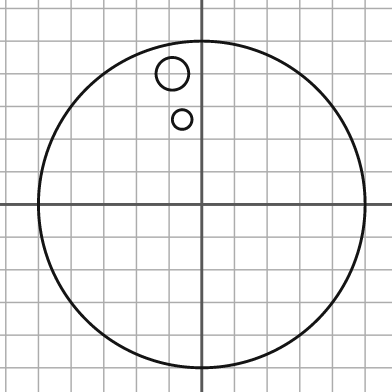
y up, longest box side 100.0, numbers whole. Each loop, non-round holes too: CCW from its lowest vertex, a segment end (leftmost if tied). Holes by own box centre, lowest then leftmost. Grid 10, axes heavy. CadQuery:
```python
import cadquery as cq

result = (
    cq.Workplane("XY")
    .moveTo(0.0, 0.0)
    .circle(50.0)
    .moveTo(-6.0, 26.0)
    .circle(3.0)
    .moveTo(-9.0, 40.0)
    .circle(5.0)
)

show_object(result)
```